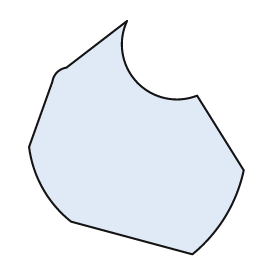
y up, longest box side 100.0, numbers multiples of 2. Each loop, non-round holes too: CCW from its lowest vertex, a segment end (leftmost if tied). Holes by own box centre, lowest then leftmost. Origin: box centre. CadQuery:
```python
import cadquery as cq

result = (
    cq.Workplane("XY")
    .moveTo(24.0, -50.0)
    .threePointArc((38.0, -34.0), (46.0, -14.0))
    .lineTo(26.0, 18.0)
    .threePointArc((0.0, 24.0), (-4.0, 50.0))
    .lineTo(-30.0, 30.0)
    .threePointArc((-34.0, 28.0), (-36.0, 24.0))
    .lineTo(-46.0, -4.0)
    .threePointArc((-40.0, -22.0), (-28.0, -36.0))
    .close()
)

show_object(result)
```